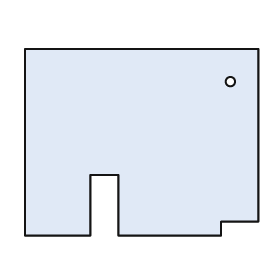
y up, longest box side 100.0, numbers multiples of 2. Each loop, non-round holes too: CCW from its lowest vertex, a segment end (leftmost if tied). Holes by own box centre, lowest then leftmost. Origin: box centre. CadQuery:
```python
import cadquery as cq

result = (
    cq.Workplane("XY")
    .moveTo(-50.0, -40.0)
    .lineTo(-22.0, -40.0)
    .lineTo(-22.0, -14.0)
    .lineTo(-10.0, -14.0)
    .lineTo(-10.0, -40.0)
    .lineTo(34.0, -40.0)
    .lineTo(34.0, -34.0)
    .lineTo(50.0, -34.0)
    .lineTo(50.0, 40.0)
    .lineTo(-50.0, 40.0)
    .close()
    .moveTo(38.0, 26.0)
    .circle(2.0)
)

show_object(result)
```